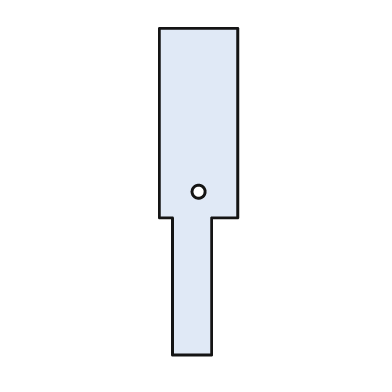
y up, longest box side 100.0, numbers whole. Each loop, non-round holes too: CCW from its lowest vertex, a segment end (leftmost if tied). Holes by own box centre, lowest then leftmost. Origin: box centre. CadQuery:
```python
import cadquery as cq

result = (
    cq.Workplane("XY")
    .moveTo(-8.0, -50.0)
    .lineTo(4.0, -50.0)
    .lineTo(4.0, -8.0)
    .lineTo(12.0, -8.0)
    .lineTo(12.0, 50.0)
    .lineTo(-12.0, 50.0)
    .lineTo(-12.0, -8.0)
    .lineTo(-8.0, -8.0)
    .close()
    .moveTo(0.0, 0.0)
    .circle(2.0)
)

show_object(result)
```